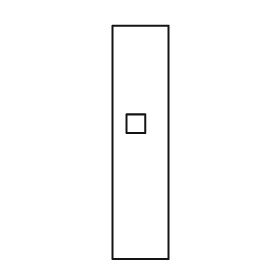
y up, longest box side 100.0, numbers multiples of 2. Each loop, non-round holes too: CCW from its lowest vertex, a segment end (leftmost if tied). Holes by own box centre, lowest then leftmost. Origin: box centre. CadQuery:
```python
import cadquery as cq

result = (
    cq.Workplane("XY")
    .moveTo(-12.0, -50.0)
    .lineTo(12.0, -50.0)
    .lineTo(12.0, 50.0)
    .lineTo(-12.0, 50.0)
    .close()
    .moveTo(-6.0, 4.0)
    .lineTo(2.0, 4.0)
    .lineTo(2.0, 12.0)
    .lineTo(-6.0, 12.0)
    .close()
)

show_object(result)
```